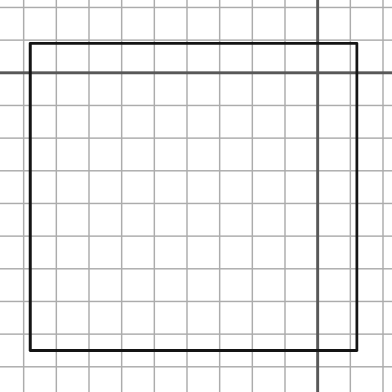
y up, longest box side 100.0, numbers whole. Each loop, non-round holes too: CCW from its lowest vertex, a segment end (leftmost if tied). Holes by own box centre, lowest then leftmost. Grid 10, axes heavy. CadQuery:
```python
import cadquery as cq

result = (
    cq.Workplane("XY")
    .moveTo(-88.0, -85.0)
    .lineTo(12.0, -85.0)
    .lineTo(12.0, 9.0)
    .lineTo(-88.0, 9.0)
    .close()
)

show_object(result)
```